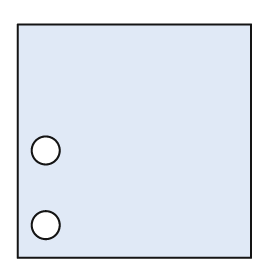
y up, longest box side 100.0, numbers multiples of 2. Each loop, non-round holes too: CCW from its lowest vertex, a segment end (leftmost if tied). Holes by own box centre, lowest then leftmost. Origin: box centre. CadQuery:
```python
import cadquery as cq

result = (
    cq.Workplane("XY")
    .moveTo(-50.0, -50.0)
    .lineTo(50.0, -50.0)
    .lineTo(50.0, 50.0)
    .lineTo(-50.0, 50.0)
    .close()
    .moveTo(-38.0, -36.0)
    .circle(6.0)
    .moveTo(-38.0, -4.0)
    .circle(6.0)
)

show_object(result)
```